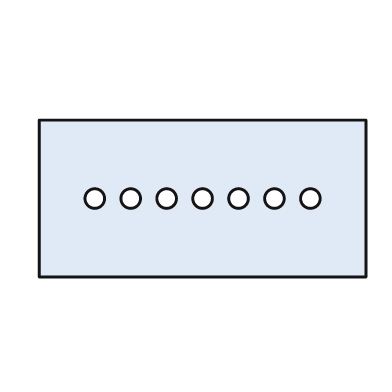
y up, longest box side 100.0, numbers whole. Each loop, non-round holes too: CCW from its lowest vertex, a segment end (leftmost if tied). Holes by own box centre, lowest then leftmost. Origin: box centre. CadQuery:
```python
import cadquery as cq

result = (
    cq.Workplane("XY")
    .moveTo(-50.0, -24.0)
    .lineTo(50.0, -24.0)
    .lineTo(50.0, 24.0)
    .lineTo(-50.0, 24.0)
    .close()
    .moveTo(-33.0, 0.0)
    .circle(3.0)
    .moveTo(-22.0, 0.0)
    .circle(3.0)
    .moveTo(-11.0, 0.0)
    .circle(3.0)
    .moveTo(0.0, 0.0)
    .circle(3.0)
    .moveTo(11.0, 0.0)
    .circle(3.0)
    .moveTo(22.0, 0.0)
    .circle(3.0)
    .moveTo(33.0, 0.0)
    .circle(3.0)
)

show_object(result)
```